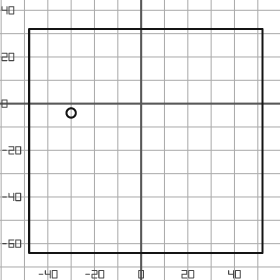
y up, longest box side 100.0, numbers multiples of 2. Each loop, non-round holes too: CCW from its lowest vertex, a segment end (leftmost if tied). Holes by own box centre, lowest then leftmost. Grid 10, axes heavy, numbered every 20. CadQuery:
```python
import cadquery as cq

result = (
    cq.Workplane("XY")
    .moveTo(-48.0, -64.0)
    .lineTo(52.0, -64.0)
    .lineTo(52.0, 32.0)
    .lineTo(-48.0, 32.0)
    .close()
    .moveTo(-30.0, -4.0)
    .circle(2.0)
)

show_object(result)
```